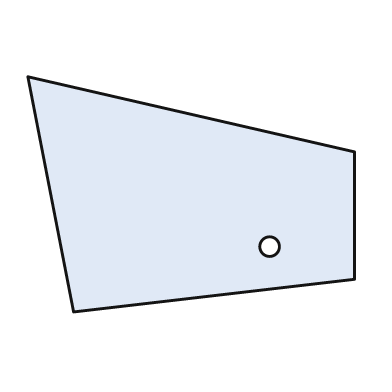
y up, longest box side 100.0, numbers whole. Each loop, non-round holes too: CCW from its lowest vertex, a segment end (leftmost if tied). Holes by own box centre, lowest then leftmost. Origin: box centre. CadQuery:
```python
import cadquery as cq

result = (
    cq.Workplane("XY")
    .moveTo(-36.0, -36.0)
    .lineTo(50.0, -26.0)
    .lineTo(50.0, 13.0)
    .lineTo(-50.0, 36.0)
    .close()
    .moveTo(24.0, -16.0)
    .circle(3.0)
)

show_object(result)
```